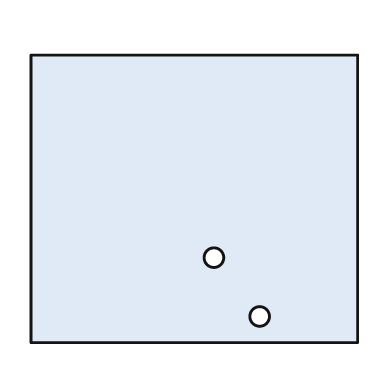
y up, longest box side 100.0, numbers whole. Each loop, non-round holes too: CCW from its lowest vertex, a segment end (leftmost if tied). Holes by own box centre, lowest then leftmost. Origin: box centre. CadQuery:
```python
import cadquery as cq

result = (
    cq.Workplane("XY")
    .moveTo(-50.0, -44.0)
    .lineTo(50.0, -44.0)
    .lineTo(50.0, 44.0)
    .lineTo(-50.0, 44.0)
    .close()
    .moveTo(20.0, -36.0)
    .circle(3.0)
    .moveTo(6.0, -18.0)
    .circle(3.0)
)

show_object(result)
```